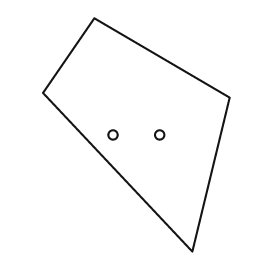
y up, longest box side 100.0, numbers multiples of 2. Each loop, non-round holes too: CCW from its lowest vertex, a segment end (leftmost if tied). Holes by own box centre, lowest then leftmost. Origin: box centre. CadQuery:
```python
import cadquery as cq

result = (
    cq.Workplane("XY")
    .moveTo(24.0, -50.0)
    .lineTo(40.0, 16.0)
    .lineTo(-18.0, 50.0)
    .lineTo(-40.0, 18.0)
    .close()
    .moveTo(-10.0, 0.0)
    .circle(2.0)
    .moveTo(10.0, 0.0)
    .circle(2.0)
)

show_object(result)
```